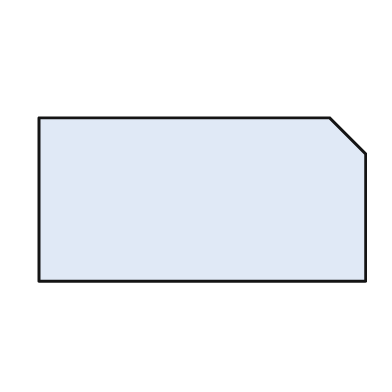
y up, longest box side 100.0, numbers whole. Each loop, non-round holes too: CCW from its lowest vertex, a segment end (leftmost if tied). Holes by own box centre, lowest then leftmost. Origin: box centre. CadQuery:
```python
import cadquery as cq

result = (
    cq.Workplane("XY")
    .moveTo(-50.0, -25.0)
    .lineTo(50.0, -25.0)
    .lineTo(50.0, 14.0)
    .lineTo(39.0, 25.0)
    .lineTo(-50.0, 25.0)
    .close()
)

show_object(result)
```